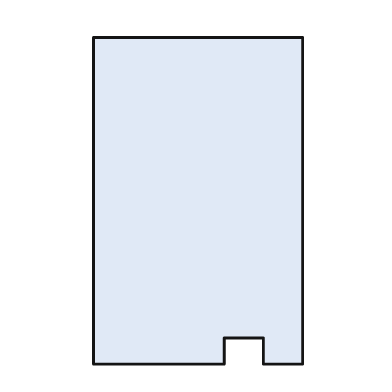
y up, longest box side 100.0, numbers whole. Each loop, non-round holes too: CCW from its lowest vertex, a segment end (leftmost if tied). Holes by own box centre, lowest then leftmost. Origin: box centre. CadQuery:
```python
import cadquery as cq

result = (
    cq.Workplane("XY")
    .moveTo(-32.0, -50.0)
    .lineTo(8.0, -50.0)
    .lineTo(8.0, -42.0)
    .lineTo(20.0, -42.0)
    .lineTo(20.0, -50.0)
    .lineTo(32.0, -50.0)
    .lineTo(32.0, 50.0)
    .lineTo(-32.0, 50.0)
    .close()
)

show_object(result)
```